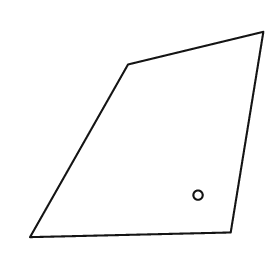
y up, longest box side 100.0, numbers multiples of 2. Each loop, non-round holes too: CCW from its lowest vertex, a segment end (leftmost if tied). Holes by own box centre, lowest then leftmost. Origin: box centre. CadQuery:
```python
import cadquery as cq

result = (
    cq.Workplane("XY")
    .moveTo(-50.0, -44.0)
    .lineTo(36.0, -42.0)
    .lineTo(50.0, 44.0)
    .lineTo(-8.0, 30.0)
    .close()
    .moveTo(22.0, -26.0)
    .circle(2.0)
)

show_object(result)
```